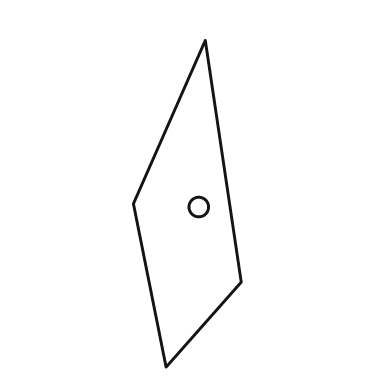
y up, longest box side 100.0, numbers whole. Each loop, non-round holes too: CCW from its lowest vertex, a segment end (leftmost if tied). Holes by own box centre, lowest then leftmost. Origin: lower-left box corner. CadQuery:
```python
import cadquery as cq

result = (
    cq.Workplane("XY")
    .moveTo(10.0, 0.0)
    .lineTo(33.0, 26.0)
    .lineTo(22.0, 100.0)
    .lineTo(0.0, 50.0)
    .close()
    .moveTo(20.0, 49.0)
    .circle(3.0)
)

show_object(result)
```